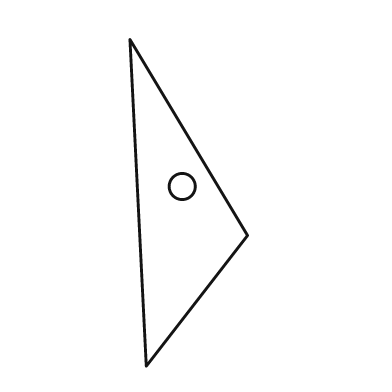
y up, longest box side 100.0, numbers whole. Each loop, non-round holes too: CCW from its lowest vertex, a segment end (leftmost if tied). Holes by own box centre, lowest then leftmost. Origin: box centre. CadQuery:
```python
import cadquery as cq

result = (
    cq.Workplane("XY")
    .moveTo(-13.0, -50.0)
    .lineTo(18.0, -10.0)
    .lineTo(-18.0, 50.0)
    .close()
    .moveTo(-2.0, 5.0)
    .circle(4.0)
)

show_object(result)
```